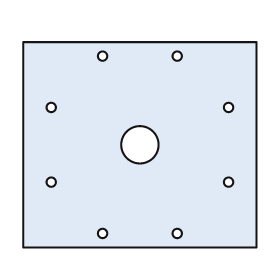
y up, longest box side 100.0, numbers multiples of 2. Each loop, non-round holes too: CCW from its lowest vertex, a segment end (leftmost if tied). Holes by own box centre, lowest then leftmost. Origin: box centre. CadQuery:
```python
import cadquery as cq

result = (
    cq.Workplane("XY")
    .moveTo(-50.0, -44.0)
    .lineTo(50.0, -44.0)
    .lineTo(50.0, 44.0)
    .lineTo(-50.0, 44.0)
    .close()
    .moveTo(-16.0, -38.0)
    .circle(2.0)
    .moveTo(16.0, -38.0)
    .circle(2.0)
    .moveTo(-38.0, -16.0)
    .circle(2.0)
    .moveTo(38.0, -16.0)
    .circle(2.0)
    .moveTo(0.0, 0.0)
    .circle(8.0)
    .moveTo(-38.0, 16.0)
    .circle(2.0)
    .moveTo(38.0, 16.0)
    .circle(2.0)
    .moveTo(-16.0, 38.0)
    .circle(2.0)
    .moveTo(16.0, 38.0)
    .circle(2.0)
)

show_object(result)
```